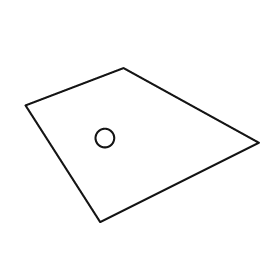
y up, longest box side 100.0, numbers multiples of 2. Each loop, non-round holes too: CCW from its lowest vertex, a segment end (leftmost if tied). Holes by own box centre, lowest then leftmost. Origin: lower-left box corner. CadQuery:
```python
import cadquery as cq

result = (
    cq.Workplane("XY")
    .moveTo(32.0, 0.0)
    .lineTo(100.0, 34.0)
    .lineTo(42.0, 66.0)
    .lineTo(0.0, 50.0)
    .close()
    .moveTo(34.0, 36.0)
    .circle(4.0)
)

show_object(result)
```